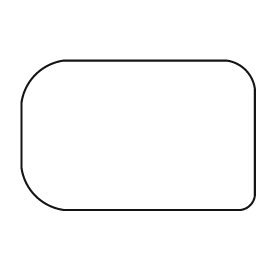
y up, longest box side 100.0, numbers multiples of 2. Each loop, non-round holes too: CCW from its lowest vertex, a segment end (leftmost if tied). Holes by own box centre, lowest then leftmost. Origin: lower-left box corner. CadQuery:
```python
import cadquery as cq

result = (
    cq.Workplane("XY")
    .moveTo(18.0, 0.0)
    .lineTo(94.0, 0.0)
    .threePointArc((98.0, 2.0), (100.0, 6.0))
    .lineTo(100.0, 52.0)
    .threePointArc((96.0, 60.0), (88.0, 64.0))
    .lineTo(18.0, 64.0)
    .threePointArc((6.0, 58.0), (0.0, 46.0))
    .lineTo(0.0, 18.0)
    .threePointArc((6.0, 6.0), (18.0, 0.0))
    .close()
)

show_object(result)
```